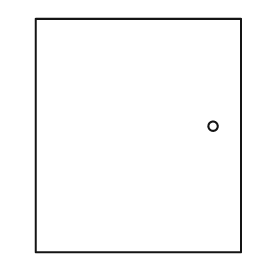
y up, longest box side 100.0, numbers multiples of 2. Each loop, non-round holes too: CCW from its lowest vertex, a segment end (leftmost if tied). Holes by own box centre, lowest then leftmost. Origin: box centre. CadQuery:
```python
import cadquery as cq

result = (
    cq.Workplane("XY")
    .moveTo(-44.0, -50.0)
    .lineTo(44.0, -50.0)
    .lineTo(44.0, 50.0)
    .lineTo(-44.0, 50.0)
    .close()
    .moveTo(32.0, 4.0)
    .circle(2.0)
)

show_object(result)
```